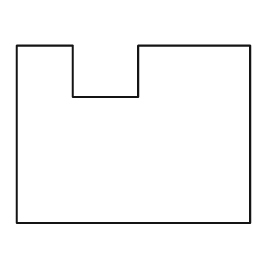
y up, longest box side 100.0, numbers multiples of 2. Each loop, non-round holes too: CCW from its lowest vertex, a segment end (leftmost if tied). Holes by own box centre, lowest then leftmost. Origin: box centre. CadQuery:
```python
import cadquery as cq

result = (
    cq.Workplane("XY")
    .moveTo(-50.0, -38.0)
    .lineTo(50.0, -38.0)
    .lineTo(50.0, 38.0)
    .lineTo(2.0, 38.0)
    .lineTo(2.0, 16.0)
    .lineTo(-26.0, 16.0)
    .lineTo(-26.0, 38.0)
    .lineTo(-50.0, 38.0)
    .close()
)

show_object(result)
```